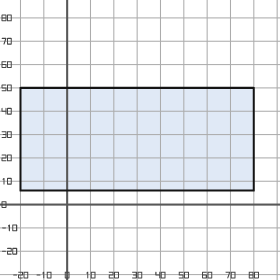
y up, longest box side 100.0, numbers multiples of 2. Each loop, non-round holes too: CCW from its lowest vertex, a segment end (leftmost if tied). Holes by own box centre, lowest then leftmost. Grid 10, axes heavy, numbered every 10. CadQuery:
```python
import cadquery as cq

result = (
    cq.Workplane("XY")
    .moveTo(-20.0, 6.0)
    .lineTo(80.0, 6.0)
    .lineTo(80.0, 50.0)
    .lineTo(-20.0, 50.0)
    .close()
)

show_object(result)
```